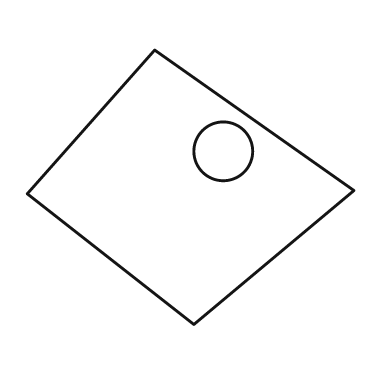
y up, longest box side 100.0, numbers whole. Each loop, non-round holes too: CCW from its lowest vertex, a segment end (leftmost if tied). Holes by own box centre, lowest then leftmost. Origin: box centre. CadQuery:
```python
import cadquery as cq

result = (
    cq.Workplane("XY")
    .moveTo(1.0, -42.0)
    .lineTo(50.0, -1.0)
    .lineTo(-11.0, 42.0)
    .lineTo(-50.0, -2.0)
    .close()
    .moveTo(10.0, 11.0)
    .circle(9.0)
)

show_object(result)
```